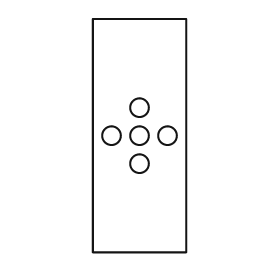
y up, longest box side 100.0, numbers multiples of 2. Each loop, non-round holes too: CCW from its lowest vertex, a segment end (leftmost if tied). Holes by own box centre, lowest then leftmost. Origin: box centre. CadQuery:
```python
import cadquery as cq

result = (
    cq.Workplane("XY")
    .moveTo(-20.0, -50.0)
    .lineTo(20.0, -50.0)
    .lineTo(20.0, 50.0)
    .lineTo(-20.0, 50.0)
    .close()
    .moveTo(0.0, -12.0)
    .circle(4.0)
    .moveTo(-12.0, 0.0)
    .circle(4.0)
    .moveTo(0.0, 0.0)
    .circle(4.0)
    .moveTo(12.0, 0.0)
    .circle(4.0)
    .moveTo(0.0, 12.0)
    .circle(4.0)
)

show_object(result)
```